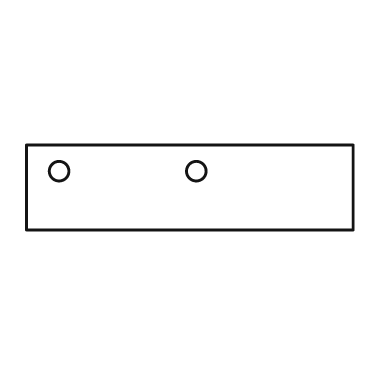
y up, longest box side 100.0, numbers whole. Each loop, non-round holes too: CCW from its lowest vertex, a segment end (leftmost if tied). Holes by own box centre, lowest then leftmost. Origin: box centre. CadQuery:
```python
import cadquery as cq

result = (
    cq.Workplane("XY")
    .moveTo(-50.0, -13.0)
    .lineTo(50.0, -13.0)
    .lineTo(50.0, 13.0)
    .lineTo(-50.0, 13.0)
    .close()
    .moveTo(-40.0, 5.0)
    .circle(3.0)
    .moveTo(2.0, 5.0)
    .circle(3.0)
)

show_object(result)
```